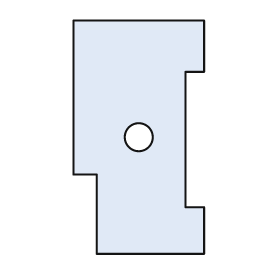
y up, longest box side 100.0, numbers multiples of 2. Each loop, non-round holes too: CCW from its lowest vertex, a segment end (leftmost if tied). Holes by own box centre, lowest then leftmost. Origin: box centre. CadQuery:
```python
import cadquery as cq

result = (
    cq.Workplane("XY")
    .moveTo(-18.0, -50.0)
    .lineTo(28.0, -50.0)
    .lineTo(28.0, -30.0)
    .lineTo(20.0, -30.0)
    .lineTo(20.0, 28.0)
    .lineTo(28.0, 28.0)
    .lineTo(28.0, 50.0)
    .lineTo(-28.0, 50.0)
    .lineTo(-28.0, -16.0)
    .lineTo(-18.0, -16.0)
    .close()
    .moveTo(0.0, 0.0)
    .circle(6.0)
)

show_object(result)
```